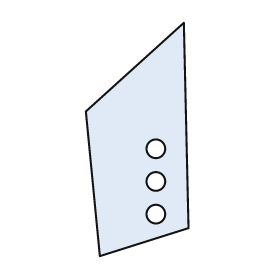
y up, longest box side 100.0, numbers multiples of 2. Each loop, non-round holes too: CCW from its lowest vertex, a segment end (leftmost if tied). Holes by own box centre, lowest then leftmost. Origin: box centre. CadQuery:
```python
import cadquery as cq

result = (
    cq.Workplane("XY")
    .moveTo(-16.0, -50.0)
    .lineTo(22.0, -38.0)
    .lineTo(20.0, 50.0)
    .lineTo(-22.0, 12.0)
    .close()
    .moveTo(8.0, -32.0)
    .circle(4.0)
    .moveTo(8.0, -18.0)
    .circle(4.0)
    .moveTo(8.0, -4.0)
    .circle(4.0)
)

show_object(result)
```